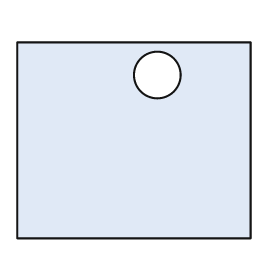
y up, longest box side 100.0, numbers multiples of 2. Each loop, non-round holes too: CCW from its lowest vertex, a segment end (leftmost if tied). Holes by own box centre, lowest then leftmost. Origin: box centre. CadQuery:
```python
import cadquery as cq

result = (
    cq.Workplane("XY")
    .moveTo(-50.0, -42.0)
    .lineTo(50.0, -42.0)
    .lineTo(50.0, 42.0)
    .lineTo(-50.0, 42.0)
    .close()
    .moveTo(10.0, 28.0)
    .circle(10.0)
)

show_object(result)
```